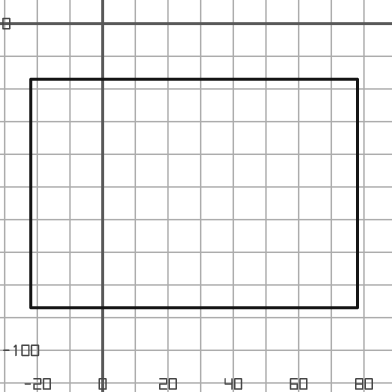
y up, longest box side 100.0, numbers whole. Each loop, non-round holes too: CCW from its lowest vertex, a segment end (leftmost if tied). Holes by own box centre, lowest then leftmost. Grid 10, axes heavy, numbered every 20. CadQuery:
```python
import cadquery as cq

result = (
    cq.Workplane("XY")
    .moveTo(-22.0, -87.0)
    .lineTo(78.0, -87.0)
    .lineTo(78.0, -17.0)
    .lineTo(-22.0, -17.0)
    .close()
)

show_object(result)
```